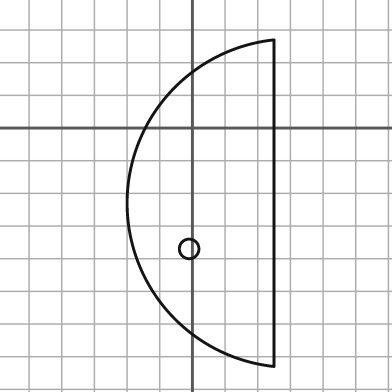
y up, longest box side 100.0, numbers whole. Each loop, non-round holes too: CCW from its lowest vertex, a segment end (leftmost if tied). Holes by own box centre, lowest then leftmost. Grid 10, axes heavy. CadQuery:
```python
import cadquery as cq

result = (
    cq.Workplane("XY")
    .moveTo(25.0, -73.0)
    .lineTo(25.0, 27.0)
    .threePointArc((-20.0, -23.0), (25.0, -73.0))
    .close()
    .moveTo(-1.0, -37.0)
    .circle(3.0)
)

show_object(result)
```